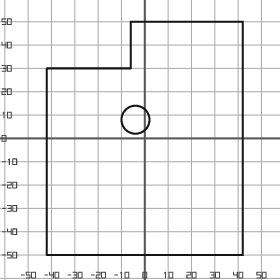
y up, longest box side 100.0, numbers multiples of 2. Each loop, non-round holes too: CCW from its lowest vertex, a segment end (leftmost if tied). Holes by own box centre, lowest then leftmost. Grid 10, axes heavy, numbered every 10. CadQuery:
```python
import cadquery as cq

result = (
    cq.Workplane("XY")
    .moveTo(-42.0, -50.0)
    .lineTo(42.0, -50.0)
    .lineTo(42.0, 50.0)
    .lineTo(-6.0, 50.0)
    .lineTo(-6.0, 30.0)
    .lineTo(-42.0, 30.0)
    .close()
    .moveTo(-4.0, 8.0)
    .circle(6.0)
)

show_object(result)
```